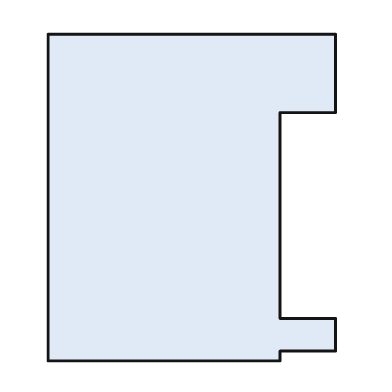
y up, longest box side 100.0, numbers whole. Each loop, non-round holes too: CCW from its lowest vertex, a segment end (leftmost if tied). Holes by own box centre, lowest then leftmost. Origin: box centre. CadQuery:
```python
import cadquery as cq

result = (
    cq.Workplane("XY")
    .moveTo(-44.0, -50.0)
    .lineTo(27.0, -50.0)
    .lineTo(27.0, -47.0)
    .lineTo(44.0, -47.0)
    .lineTo(44.0, -37.0)
    .lineTo(27.0, -37.0)
    .lineTo(27.0, 26.0)
    .lineTo(44.0, 26.0)
    .lineTo(44.0, 50.0)
    .lineTo(-44.0, 50.0)
    .close()
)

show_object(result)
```